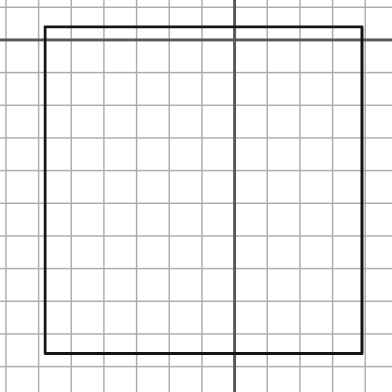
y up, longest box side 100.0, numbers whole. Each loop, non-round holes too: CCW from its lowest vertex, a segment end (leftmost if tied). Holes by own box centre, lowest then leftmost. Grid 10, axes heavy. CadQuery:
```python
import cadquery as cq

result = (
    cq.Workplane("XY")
    .moveTo(-58.0, -96.0)
    .lineTo(39.0, -96.0)
    .lineTo(39.0, 4.0)
    .lineTo(-58.0, 4.0)
    .close()
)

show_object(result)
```